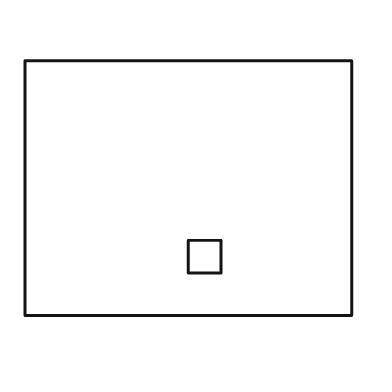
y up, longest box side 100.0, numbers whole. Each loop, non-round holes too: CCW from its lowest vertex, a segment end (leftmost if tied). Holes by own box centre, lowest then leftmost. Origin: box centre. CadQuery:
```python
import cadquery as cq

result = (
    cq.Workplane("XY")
    .moveTo(-50.0, -39.0)
    .lineTo(50.0, -39.0)
    .lineTo(50.0, 39.0)
    .lineTo(-50.0, 39.0)
    .close()
    .moveTo(0.0, -26.0)
    .lineTo(10.0, -26.0)
    .lineTo(10.0, -16.0)
    .lineTo(0.0, -16.0)
    .close()
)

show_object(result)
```